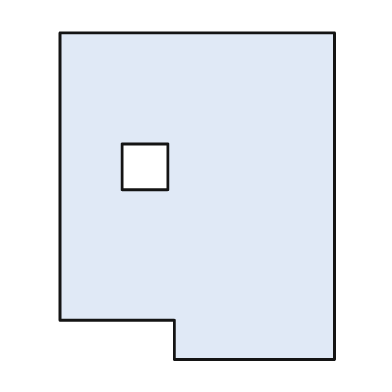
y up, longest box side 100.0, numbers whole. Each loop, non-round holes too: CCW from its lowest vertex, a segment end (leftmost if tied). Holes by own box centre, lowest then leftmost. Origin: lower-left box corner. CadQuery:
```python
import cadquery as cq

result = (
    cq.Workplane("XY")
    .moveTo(35.0, 0.0)
    .lineTo(84.0, 0.0)
    .lineTo(84.0, 100.0)
    .lineTo(0.0, 100.0)
    .lineTo(0.0, 12.0)
    .lineTo(35.0, 12.0)
    .close()
    .moveTo(19.0, 52.0)
    .lineTo(33.0, 52.0)
    .lineTo(33.0, 66.0)
    .lineTo(19.0, 66.0)
    .close()
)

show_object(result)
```